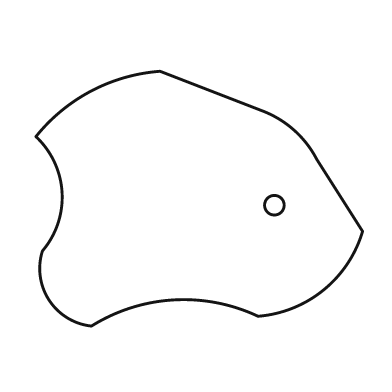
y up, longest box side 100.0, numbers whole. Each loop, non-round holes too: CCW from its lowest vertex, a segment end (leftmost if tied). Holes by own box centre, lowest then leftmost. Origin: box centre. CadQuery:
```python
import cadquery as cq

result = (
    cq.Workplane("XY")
    .moveTo(-33.0, -39.0)
    .threePointArc((-8.0, -31.0), (18.0, -36.0))
    .threePointArc((38.0, -28.0), (50.0, -10.0))
    .lineTo(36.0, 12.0)
    .threePointArc((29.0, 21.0), (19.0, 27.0))
    .lineTo(-12.0, 39.0)
    .threePointArc((-33.0, 33.0), (-50.0, 19.0))
    .threePointArc((-42.0, 2.0), (-48.0, -16.0))
    .threePointArc((-46.0, -31.0), (-33.0, -39.0))
    .close()
    .moveTo(23.0, -2.0)
    .circle(3.0)
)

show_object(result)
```